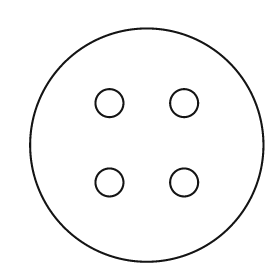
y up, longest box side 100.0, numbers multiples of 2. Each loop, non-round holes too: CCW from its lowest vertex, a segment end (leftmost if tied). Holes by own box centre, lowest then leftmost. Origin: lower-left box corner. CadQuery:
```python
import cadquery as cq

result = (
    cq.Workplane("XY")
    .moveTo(50.0, 50.0)
    .circle(50.0)
    .moveTo(34.0, 34.0)
    .circle(6.0)
    .moveTo(66.0, 34.0)
    .circle(6.0)
    .moveTo(34.0, 68.0)
    .circle(6.0)
    .moveTo(66.0, 68.0)
    .circle(6.0)
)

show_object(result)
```